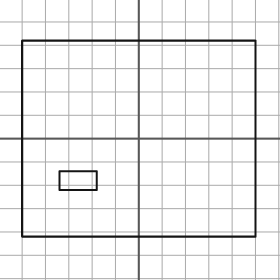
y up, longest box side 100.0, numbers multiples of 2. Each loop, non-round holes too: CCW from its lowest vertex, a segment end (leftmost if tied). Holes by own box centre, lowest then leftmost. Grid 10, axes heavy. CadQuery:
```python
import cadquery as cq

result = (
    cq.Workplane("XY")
    .moveTo(-50.0, -42.0)
    .lineTo(50.0, -42.0)
    .lineTo(50.0, 42.0)
    .lineTo(-50.0, 42.0)
    .close()
    .moveTo(-34.0, -22.0)
    .lineTo(-18.0, -22.0)
    .lineTo(-18.0, -14.0)
    .lineTo(-34.0, -14.0)
    .close()
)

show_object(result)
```